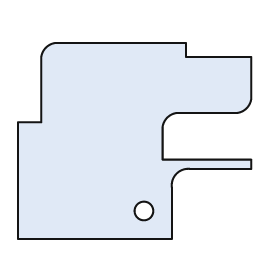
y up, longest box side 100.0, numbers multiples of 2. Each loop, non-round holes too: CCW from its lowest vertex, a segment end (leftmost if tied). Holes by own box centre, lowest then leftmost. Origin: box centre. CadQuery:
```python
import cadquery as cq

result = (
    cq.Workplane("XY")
    .moveTo(-50.0, -42.0)
    .lineTo(16.0, -42.0)
    .lineTo(16.0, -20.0)
    .threePointArc((18.0, -14.0), (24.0, -12.0))
    .lineTo(50.0, -12.0)
    .lineTo(50.0, -8.0)
    .lineTo(12.0, -8.0)
    .lineTo(12.0, 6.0)
    .threePointArc((14.0, 10.0), (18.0, 12.0))
    .lineTo(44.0, 12.0)
    .threePointArc((48.0, 14.0), (50.0, 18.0))
    .lineTo(50.0, 36.0)
    .lineTo(22.0, 36.0)
    .lineTo(22.0, 42.0)
    .lineTo(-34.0, 42.0)
    .threePointArc((-38.0, 40.0), (-40.0, 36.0))
    .lineTo(-40.0, 8.0)
    .lineTo(-50.0, 8.0)
    .close()
    .moveTo(4.0, -30.0)
    .circle(4.0)
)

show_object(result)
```